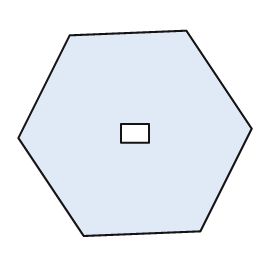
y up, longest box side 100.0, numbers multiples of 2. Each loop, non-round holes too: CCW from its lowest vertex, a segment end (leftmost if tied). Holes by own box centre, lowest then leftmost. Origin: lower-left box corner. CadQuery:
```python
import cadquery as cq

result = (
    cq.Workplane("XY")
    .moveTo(28.0, 0.0)
    .lineTo(78.0, 2.0)
    .lineTo(100.0, 46.0)
    .lineTo(72.0, 88.0)
    .lineTo(22.0, 86.0)
    .lineTo(0.0, 42.0)
    .close()
    .moveTo(44.0, 40.0)
    .lineTo(56.0, 40.0)
    .lineTo(56.0, 48.0)
    .lineTo(44.0, 48.0)
    .close()
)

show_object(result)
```